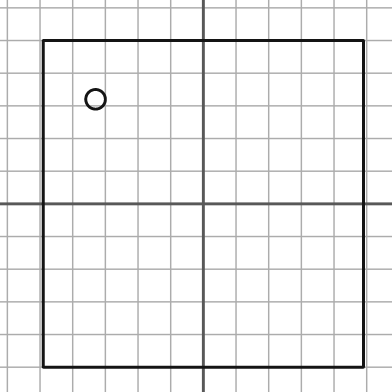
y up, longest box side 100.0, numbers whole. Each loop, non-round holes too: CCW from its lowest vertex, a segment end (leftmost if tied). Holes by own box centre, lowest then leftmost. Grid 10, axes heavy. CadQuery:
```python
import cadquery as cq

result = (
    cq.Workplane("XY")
    .moveTo(-49.0, -50.0)
    .lineTo(49.0, -50.0)
    .lineTo(49.0, 50.0)
    .lineTo(-49.0, 50.0)
    .close()
    .moveTo(-33.0, 32.0)
    .circle(3.0)
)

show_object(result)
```